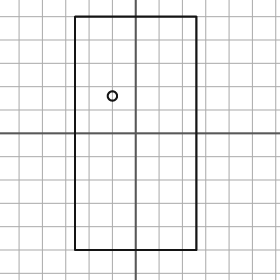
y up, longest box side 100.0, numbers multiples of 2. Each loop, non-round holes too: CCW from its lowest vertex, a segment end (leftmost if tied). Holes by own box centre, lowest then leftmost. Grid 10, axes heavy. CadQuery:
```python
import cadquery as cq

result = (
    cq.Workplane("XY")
    .moveTo(-26.0, -50.0)
    .lineTo(26.0, -50.0)
    .lineTo(26.0, 50.0)
    .lineTo(-26.0, 50.0)
    .close()
    .moveTo(-10.0, 16.0)
    .circle(2.0)
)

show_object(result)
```